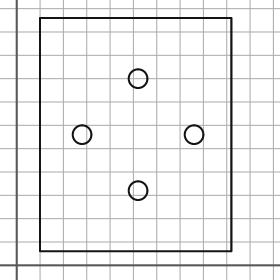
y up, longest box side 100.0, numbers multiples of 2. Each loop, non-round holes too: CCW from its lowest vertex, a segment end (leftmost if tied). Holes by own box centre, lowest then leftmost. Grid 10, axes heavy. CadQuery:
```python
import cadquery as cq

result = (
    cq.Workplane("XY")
    .moveTo(10.0, 6.0)
    .lineTo(92.0, 6.0)
    .lineTo(92.0, 106.0)
    .lineTo(10.0, 106.0)
    .close()
    .moveTo(52.0, 32.0)
    .circle(4.0)
    .moveTo(28.0, 56.0)
    .circle(4.0)
    .moveTo(76.0, 56.0)
    .circle(4.0)
    .moveTo(52.0, 80.0)
    .circle(4.0)
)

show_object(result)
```